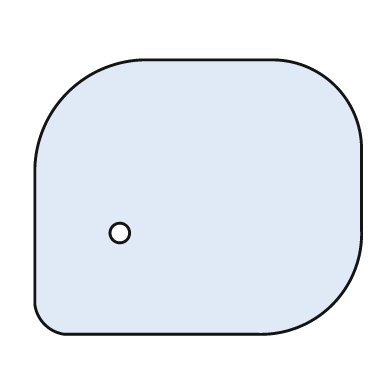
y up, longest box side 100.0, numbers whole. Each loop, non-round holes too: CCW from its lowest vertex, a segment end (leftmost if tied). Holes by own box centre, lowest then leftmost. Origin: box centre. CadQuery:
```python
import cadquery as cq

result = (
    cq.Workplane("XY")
    .moveTo(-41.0, -42.0)
    .lineTo(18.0, -42.0)
    .threePointArc((41.0, -33.0), (50.0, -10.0))
    .lineTo(50.0, 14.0)
    .threePointArc((42.0, 34.0), (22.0, 42.0))
    .lineTo(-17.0, 42.0)
    .threePointArc((-40.0, 32.0), (-50.0, 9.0))
    .lineTo(-50.0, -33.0)
    .threePointArc((-47.0, -39.0), (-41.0, -42.0))
    .close()
    .moveTo(-24.0, -11.0)
    .circle(3.0)
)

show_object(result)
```